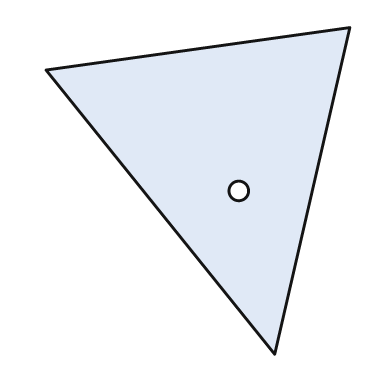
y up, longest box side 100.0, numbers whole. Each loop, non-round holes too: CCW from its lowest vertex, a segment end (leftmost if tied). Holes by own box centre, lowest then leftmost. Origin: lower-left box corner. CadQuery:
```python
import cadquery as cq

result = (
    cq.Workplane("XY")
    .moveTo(70.0, 0.0)
    .lineTo(93.0, 100.0)
    .lineTo(0.0, 87.0)
    .close()
    .moveTo(59.0, 50.0)
    .circle(3.0)
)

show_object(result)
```